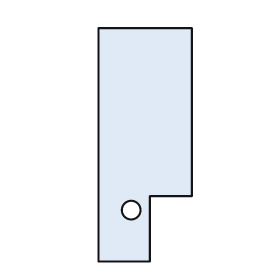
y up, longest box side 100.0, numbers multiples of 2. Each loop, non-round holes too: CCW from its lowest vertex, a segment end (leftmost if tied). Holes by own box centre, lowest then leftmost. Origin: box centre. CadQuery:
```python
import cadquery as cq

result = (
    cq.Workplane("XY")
    .moveTo(-20.0, -50.0)
    .lineTo(2.0, -50.0)
    .lineTo(2.0, -22.0)
    .lineTo(20.0, -22.0)
    .lineTo(20.0, 50.0)
    .lineTo(-20.0, 50.0)
    .close()
    .moveTo(-6.0, -28.0)
    .circle(4.0)
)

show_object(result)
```